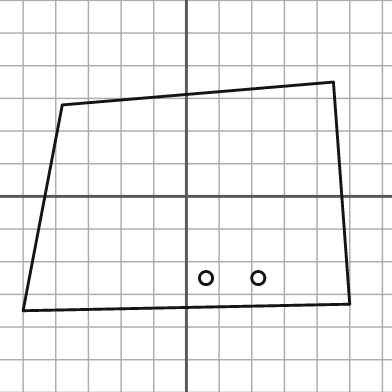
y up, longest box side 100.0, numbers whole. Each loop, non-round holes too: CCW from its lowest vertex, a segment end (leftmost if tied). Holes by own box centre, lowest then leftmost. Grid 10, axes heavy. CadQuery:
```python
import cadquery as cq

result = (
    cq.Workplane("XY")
    .moveTo(-50.0, -35.0)
    .lineTo(50.0, -33.0)
    .lineTo(45.0, 35.0)
    .lineTo(-38.0, 28.0)
    .close()
    .moveTo(6.0, -25.0)
    .circle(2.0)
    .moveTo(22.0, -25.0)
    .circle(2.0)
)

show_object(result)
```